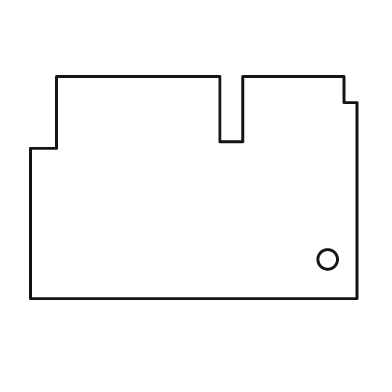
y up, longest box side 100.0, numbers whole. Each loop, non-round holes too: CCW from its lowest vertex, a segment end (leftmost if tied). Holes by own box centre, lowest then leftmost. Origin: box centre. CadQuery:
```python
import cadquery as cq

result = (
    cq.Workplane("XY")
    .moveTo(-50.0, -34.0)
    .lineTo(50.0, -34.0)
    .lineTo(50.0, 26.0)
    .lineTo(46.0, 26.0)
    .lineTo(46.0, 34.0)
    .lineTo(15.0, 34.0)
    .lineTo(15.0, 14.0)
    .lineTo(8.0, 14.0)
    .lineTo(8.0, 34.0)
    .lineTo(-42.0, 34.0)
    .lineTo(-42.0, 12.0)
    .lineTo(-50.0, 12.0)
    .close()
    .moveTo(41.0, -22.0)
    .circle(3.0)
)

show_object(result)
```